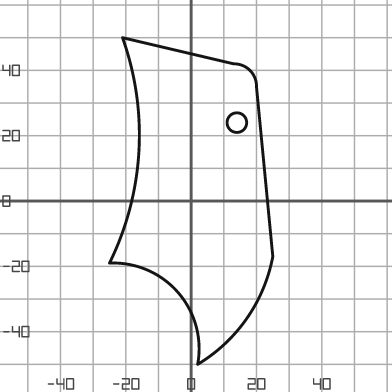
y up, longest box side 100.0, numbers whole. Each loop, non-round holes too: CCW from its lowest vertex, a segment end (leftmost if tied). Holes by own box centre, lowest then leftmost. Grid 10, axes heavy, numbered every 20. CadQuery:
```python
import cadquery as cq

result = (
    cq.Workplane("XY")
    .moveTo(2.0, -50.0)
    .threePointArc((17.0, -36.0), (25.0, -17.0))
    .lineTo(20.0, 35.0)
    .threePointArc((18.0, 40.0), (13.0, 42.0))
    .lineTo(-21.0, 50.0)
    .threePointArc((-16.0, 15.0), (-25.0, -19.0))
    .threePointArc((-4.0, -28.0), (2.0, -50.0))
    .close()
    .moveTo(14.0, 24.0)
    .circle(3.0)
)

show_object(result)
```